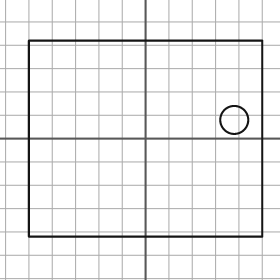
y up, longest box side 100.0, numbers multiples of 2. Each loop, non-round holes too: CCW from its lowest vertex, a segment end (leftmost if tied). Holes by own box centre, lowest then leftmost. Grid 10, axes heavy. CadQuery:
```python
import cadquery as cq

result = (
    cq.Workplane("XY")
    .moveTo(-50.0, -42.0)
    .lineTo(50.0, -42.0)
    .lineTo(50.0, 42.0)
    .lineTo(-50.0, 42.0)
    .close()
    .moveTo(38.0, 8.0)
    .circle(6.0)
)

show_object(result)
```